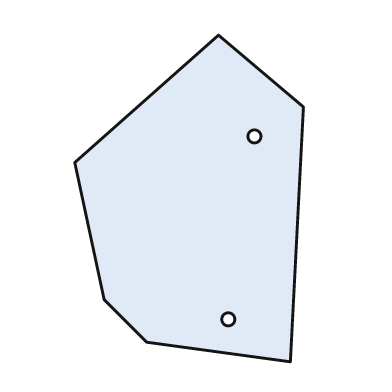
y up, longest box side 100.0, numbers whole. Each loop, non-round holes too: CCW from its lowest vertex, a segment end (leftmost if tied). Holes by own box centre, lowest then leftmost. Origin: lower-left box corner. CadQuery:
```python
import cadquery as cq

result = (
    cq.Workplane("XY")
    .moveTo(66.0, 0.0)
    .lineTo(70.0, 78.0)
    .lineTo(44.0, 100.0)
    .lineTo(0.0, 61.0)
    .lineTo(9.0, 19.0)
    .lineTo(22.0, 6.0)
    .close()
    .moveTo(47.0, 13.0)
    .circle(2.0)
    .moveTo(55.0, 69.0)
    .circle(2.0)
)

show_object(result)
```